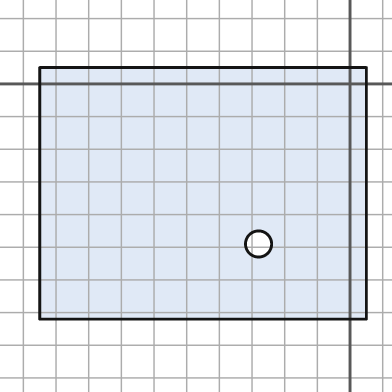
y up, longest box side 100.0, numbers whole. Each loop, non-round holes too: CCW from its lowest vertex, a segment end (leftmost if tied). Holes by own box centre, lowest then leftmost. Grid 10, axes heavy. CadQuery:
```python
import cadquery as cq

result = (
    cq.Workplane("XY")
    .moveTo(-95.0, -72.0)
    .lineTo(5.0, -72.0)
    .lineTo(5.0, 5.0)
    .lineTo(-95.0, 5.0)
    .close()
    .moveTo(-28.0, -49.0)
    .circle(4.0)
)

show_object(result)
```